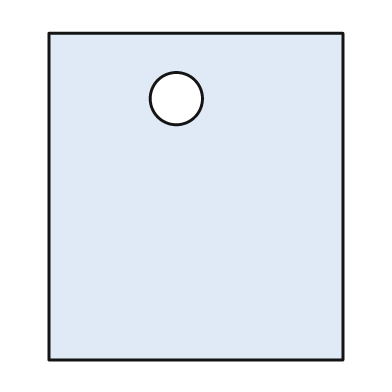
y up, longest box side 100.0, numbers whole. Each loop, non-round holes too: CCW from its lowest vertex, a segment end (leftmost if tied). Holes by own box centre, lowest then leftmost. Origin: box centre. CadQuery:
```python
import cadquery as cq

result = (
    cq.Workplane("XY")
    .moveTo(-45.0, -50.0)
    .lineTo(45.0, -50.0)
    .lineTo(45.0, 50.0)
    .lineTo(-45.0, 50.0)
    .close()
    .moveTo(-6.0, 30.0)
    .circle(8.0)
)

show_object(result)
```